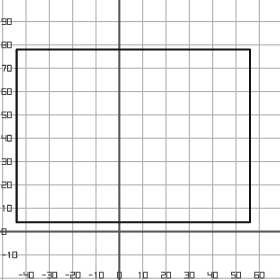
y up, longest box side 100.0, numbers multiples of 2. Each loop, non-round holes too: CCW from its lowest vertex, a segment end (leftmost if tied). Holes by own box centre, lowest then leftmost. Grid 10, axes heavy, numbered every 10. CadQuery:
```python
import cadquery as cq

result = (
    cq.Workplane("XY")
    .moveTo(-44.0, 4.0)
    .lineTo(56.0, 4.0)
    .lineTo(56.0, 78.0)
    .lineTo(-44.0, 78.0)
    .close()
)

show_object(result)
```